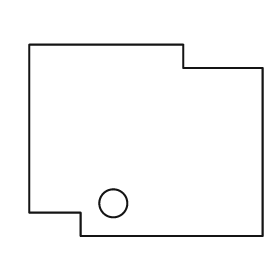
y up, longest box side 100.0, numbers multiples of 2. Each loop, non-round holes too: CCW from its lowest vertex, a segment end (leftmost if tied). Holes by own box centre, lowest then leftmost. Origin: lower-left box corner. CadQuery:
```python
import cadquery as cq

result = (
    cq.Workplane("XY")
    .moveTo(22.0, 0.0)
    .lineTo(100.0, 0.0)
    .lineTo(100.0, 72.0)
    .lineTo(66.0, 72.0)
    .lineTo(66.0, 82.0)
    .lineTo(0.0, 82.0)
    .lineTo(0.0, 10.0)
    .lineTo(22.0, 10.0)
    .close()
    .moveTo(36.0, 14.0)
    .circle(6.0)
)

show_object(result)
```